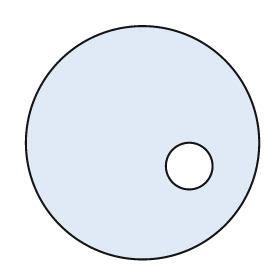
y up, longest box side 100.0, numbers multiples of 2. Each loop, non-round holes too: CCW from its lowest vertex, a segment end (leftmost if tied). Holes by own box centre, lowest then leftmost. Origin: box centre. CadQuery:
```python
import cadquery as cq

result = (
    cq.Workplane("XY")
    .moveTo(0.0, 0.0)
    .circle(50.0)
    .moveTo(20.0, -10.0)
    .circle(10.0)
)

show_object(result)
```